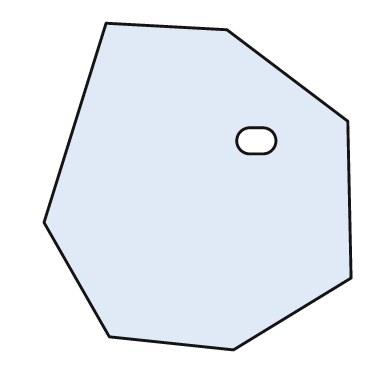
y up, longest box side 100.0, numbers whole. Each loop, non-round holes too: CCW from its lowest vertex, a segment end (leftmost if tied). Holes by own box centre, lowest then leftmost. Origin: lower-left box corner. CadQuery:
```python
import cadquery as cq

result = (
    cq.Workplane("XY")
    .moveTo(58.0, 0.0)
    .lineTo(94.0, 22.0)
    .lineTo(93.0, 70.0)
    .lineTo(56.0, 98.0)
    .lineTo(19.0, 100.0)
    .lineTo(0.0, 39.0)
    .lineTo(20.0, 4.0)
    .close()
    .moveTo(63.0, 60.0)
    .lineTo(67.0, 60.0)
    .threePointArc((71.0, 64.0), (67.0, 68.0))
    .lineTo(63.0, 68.0)
    .threePointArc((59.0, 64.0), (63.0, 60.0))
    .close()
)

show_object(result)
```